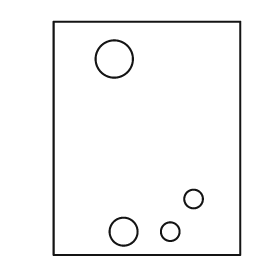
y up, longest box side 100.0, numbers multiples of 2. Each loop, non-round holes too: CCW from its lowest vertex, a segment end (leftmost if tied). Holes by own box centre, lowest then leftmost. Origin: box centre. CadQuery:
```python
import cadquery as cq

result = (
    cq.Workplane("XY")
    .moveTo(-40.0, -50.0)
    .lineTo(40.0, -50.0)
    .lineTo(40.0, 50.0)
    .lineTo(-40.0, 50.0)
    .close()
    .moveTo(-10.0, -40.0)
    .circle(6.0)
    .moveTo(10.0, -40.0)
    .circle(4.0)
    .moveTo(20.0, -26.0)
    .circle(4.0)
    .moveTo(-14.0, 34.0)
    .circle(8.0)
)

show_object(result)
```